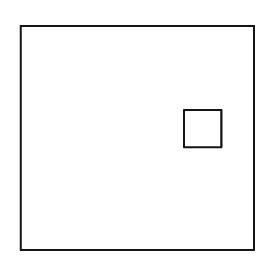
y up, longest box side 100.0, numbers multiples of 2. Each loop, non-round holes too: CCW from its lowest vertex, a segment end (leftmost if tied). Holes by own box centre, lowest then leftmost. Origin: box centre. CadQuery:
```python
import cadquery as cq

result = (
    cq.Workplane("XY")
    .moveTo(-50.0, -48.0)
    .lineTo(50.0, -48.0)
    .lineTo(50.0, 48.0)
    .lineTo(-50.0, 48.0)
    .close()
    .moveTo(20.0, -4.0)
    .lineTo(36.0, -4.0)
    .lineTo(36.0, 12.0)
    .lineTo(20.0, 12.0)
    .close()
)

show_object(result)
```